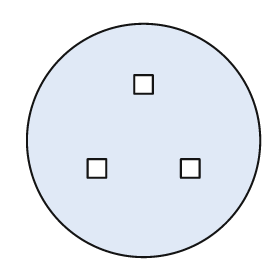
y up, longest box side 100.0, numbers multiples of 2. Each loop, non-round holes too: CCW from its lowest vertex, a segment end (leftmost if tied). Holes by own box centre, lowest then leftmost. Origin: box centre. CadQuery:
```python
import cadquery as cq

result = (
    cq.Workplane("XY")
    .moveTo(0.0, 0.0)
    .circle(50.0)
    .moveTo(-24.0, -16.0)
    .lineTo(-16.0, -16.0)
    .lineTo(-16.0, -8.0)
    .lineTo(-24.0, -8.0)
    .close()
    .moveTo(16.0, -16.0)
    .lineTo(24.0, -16.0)
    .lineTo(24.0, -8.0)
    .lineTo(16.0, -8.0)
    .close()
    .moveTo(-4.0, 20.0)
    .lineTo(4.0, 20.0)
    .lineTo(4.0, 28.0)
    .lineTo(-4.0, 28.0)
    .close()
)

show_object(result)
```